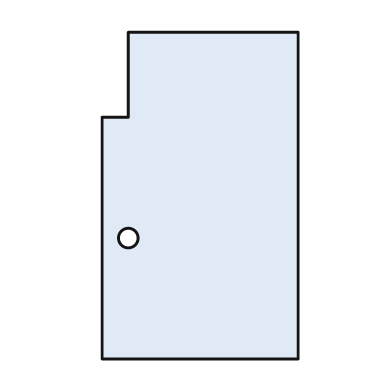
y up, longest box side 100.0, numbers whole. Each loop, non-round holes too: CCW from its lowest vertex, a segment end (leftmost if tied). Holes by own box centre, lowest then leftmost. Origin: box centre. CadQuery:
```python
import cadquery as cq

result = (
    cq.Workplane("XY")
    .moveTo(-30.0, -50.0)
    .lineTo(30.0, -50.0)
    .lineTo(30.0, 50.0)
    .lineTo(-22.0, 50.0)
    .lineTo(-22.0, 24.0)
    .lineTo(-30.0, 24.0)
    .close()
    .moveTo(-22.0, -13.0)
    .circle(3.0)
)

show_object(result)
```